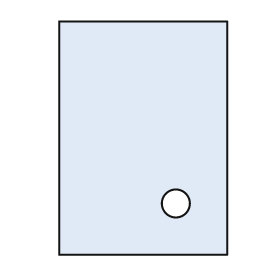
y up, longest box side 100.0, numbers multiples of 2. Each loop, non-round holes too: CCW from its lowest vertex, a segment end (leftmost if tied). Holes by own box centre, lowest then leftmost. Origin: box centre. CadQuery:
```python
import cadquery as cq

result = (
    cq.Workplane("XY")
    .moveTo(-36.0, -50.0)
    .lineTo(36.0, -50.0)
    .lineTo(36.0, 50.0)
    .lineTo(-36.0, 50.0)
    .close()
    .moveTo(14.0, -28.0)
    .circle(6.0)
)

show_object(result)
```